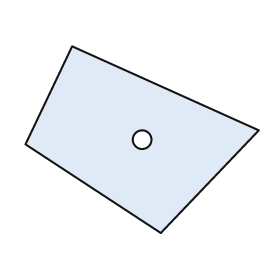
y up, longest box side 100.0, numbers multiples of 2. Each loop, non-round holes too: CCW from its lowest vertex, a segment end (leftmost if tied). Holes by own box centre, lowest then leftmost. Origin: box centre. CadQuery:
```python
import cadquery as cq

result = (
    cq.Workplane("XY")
    .moveTo(8.0, -40.0)
    .lineTo(50.0, 4.0)
    .lineTo(-30.0, 40.0)
    .lineTo(-50.0, -2.0)
    .close()
    .moveTo(0.0, 0.0)
    .circle(4.0)
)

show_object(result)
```